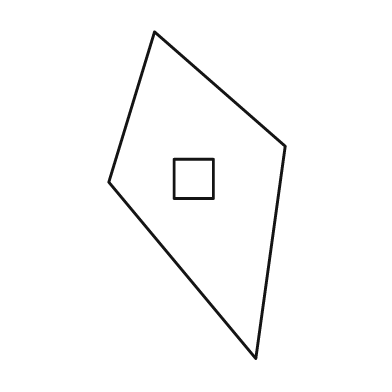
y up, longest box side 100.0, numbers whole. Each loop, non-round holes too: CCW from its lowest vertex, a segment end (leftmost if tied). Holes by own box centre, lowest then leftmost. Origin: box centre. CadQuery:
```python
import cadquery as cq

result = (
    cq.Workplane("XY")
    .moveTo(18.0, -50.0)
    .lineTo(27.0, 15.0)
    .lineTo(-13.0, 50.0)
    .lineTo(-27.0, 4.0)
    .close()
    .moveTo(-7.0, -1.0)
    .lineTo(5.0, -1.0)
    .lineTo(5.0, 11.0)
    .lineTo(-7.0, 11.0)
    .close()
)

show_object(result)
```